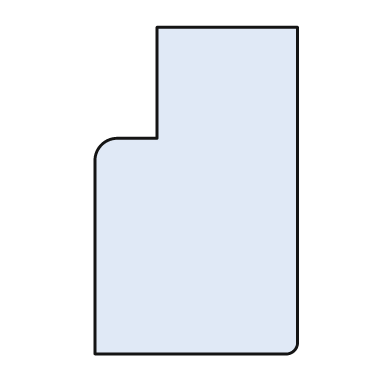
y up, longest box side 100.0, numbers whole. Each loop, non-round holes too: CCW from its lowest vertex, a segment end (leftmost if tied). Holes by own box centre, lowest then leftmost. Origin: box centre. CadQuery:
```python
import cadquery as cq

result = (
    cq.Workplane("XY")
    .moveTo(-31.0, -50.0)
    .lineTo(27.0, -50.0)
    .threePointArc((30.0, -49.0), (31.0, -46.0))
    .lineTo(31.0, 50.0)
    .lineTo(-12.0, 50.0)
    .lineTo(-12.0, 16.0)
    .lineTo(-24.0, 16.0)
    .threePointArc((-29.0, 14.0), (-31.0, 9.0))
    .close()
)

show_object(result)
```